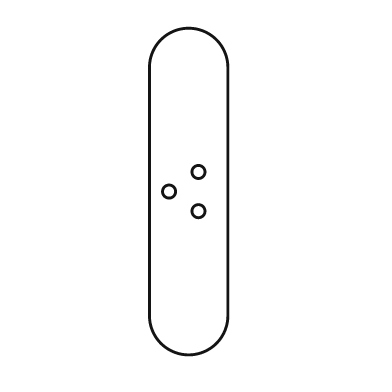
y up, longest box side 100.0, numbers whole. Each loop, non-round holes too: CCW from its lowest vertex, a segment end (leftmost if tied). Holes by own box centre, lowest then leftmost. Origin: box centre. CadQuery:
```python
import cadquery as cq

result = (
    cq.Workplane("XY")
    .moveTo(-12.0, -38.0)
    .threePointArc((0.0, -50.0), (12.0, -38.0))
    .lineTo(12.0, 38.0)
    .threePointArc((0.0, 50.0), (-12.0, 38.0))
    .close()
    .moveTo(3.0, -6.0)
    .circle(2.0)
    .moveTo(-6.0, 0.0)
    .circle(2.0)
    .moveTo(3.0, 6.0)
    .circle(2.0)
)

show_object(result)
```